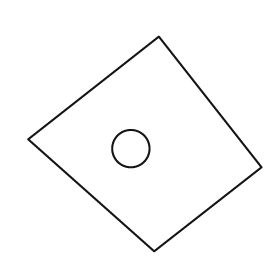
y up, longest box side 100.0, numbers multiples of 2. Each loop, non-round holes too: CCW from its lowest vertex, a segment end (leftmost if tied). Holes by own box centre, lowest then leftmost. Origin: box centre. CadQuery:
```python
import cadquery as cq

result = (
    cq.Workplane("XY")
    .moveTo(4.0, -46.0)
    .lineTo(50.0, -10.0)
    .lineTo(6.0, 46.0)
    .lineTo(-50.0, 2.0)
    .close()
    .moveTo(-6.0, -2.0)
    .circle(8.0)
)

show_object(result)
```